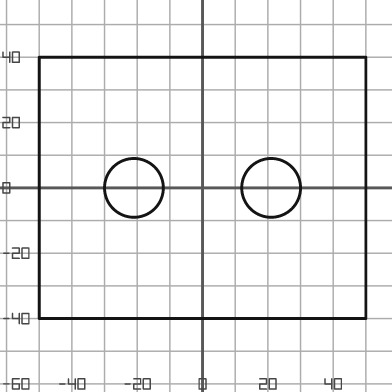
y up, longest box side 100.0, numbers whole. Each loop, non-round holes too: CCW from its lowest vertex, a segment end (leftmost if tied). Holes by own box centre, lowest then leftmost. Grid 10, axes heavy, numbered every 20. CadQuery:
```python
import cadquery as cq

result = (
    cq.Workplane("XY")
    .moveTo(-50.0, -40.0)
    .lineTo(50.0, -40.0)
    .lineTo(50.0, 40.0)
    .lineTo(-50.0, 40.0)
    .close()
    .moveTo(-21.0, 0.0)
    .circle(9.0)
    .moveTo(21.0, 0.0)
    .circle(9.0)
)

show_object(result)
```